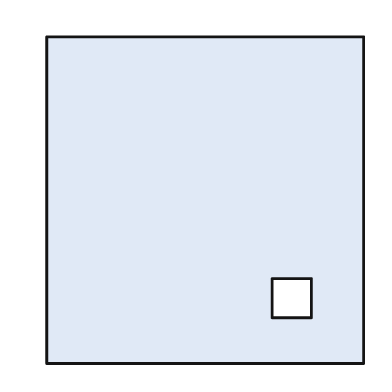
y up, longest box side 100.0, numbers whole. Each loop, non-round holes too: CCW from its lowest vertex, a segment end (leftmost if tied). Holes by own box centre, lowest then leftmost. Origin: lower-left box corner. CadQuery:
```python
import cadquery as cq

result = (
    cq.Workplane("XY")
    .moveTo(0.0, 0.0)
    .lineTo(97.0, 0.0)
    .lineTo(97.0, 100.0)
    .lineTo(0.0, 100.0)
    .close()
    .moveTo(69.0, 14.0)
    .lineTo(81.0, 14.0)
    .lineTo(81.0, 26.0)
    .lineTo(69.0, 26.0)
    .close()
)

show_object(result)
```